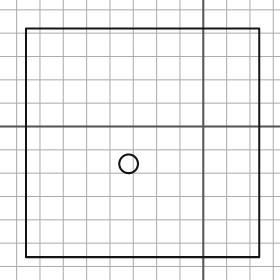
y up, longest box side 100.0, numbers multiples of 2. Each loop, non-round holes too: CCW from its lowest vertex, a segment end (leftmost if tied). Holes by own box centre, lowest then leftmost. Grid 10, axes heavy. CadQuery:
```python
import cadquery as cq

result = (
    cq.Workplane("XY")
    .moveTo(-76.0, -56.0)
    .lineTo(24.0, -56.0)
    .lineTo(24.0, 42.0)
    .lineTo(-76.0, 42.0)
    .close()
    .moveTo(-32.0, -16.0)
    .circle(4.0)
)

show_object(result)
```